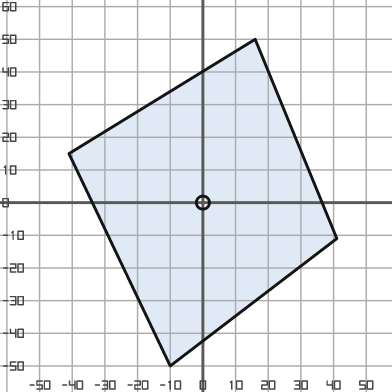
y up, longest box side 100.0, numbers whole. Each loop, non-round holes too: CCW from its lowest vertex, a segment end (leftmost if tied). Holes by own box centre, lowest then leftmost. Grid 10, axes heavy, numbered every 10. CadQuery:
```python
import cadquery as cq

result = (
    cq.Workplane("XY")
    .moveTo(-10.0, -50.0)
    .lineTo(41.0, -11.0)
    .lineTo(16.0, 50.0)
    .lineTo(-41.0, 15.0)
    .close()
    .moveTo(0.0, 0.0)
    .circle(2.0)
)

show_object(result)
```